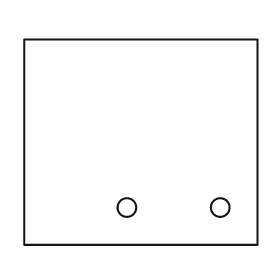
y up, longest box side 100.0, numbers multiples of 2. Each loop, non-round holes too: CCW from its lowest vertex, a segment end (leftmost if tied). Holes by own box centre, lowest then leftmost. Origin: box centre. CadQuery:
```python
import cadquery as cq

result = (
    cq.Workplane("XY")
    .moveTo(-50.0, -44.0)
    .lineTo(50.0, -44.0)
    .lineTo(50.0, 44.0)
    .lineTo(-50.0, 44.0)
    .close()
    .moveTo(-6.0, -28.0)
    .circle(4.0)
    .moveTo(34.0, -28.0)
    .circle(4.0)
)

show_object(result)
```